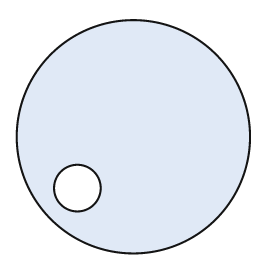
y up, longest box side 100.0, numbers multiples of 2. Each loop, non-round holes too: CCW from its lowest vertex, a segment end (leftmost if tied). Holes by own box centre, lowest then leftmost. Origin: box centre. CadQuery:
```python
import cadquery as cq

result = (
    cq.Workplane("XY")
    .moveTo(0.0, 0.0)
    .circle(50.0)
    .moveTo(-24.0, -22.0)
    .circle(10.0)
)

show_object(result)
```